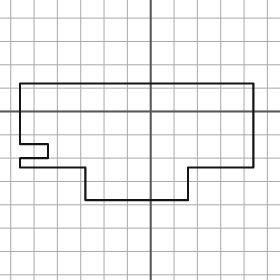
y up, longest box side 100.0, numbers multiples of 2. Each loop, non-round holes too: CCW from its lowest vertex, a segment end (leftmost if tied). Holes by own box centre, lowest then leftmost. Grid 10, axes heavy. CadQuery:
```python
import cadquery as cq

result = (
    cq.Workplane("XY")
    .moveTo(-28.0, -38.0)
    .lineTo(16.0, -38.0)
    .lineTo(16.0, -24.0)
    .lineTo(44.0, -24.0)
    .lineTo(44.0, 12.0)
    .lineTo(-56.0, 12.0)
    .lineTo(-56.0, -14.0)
    .lineTo(-44.0, -14.0)
    .lineTo(-44.0, -20.0)
    .lineTo(-56.0, -20.0)
    .lineTo(-56.0, -24.0)
    .lineTo(-28.0, -24.0)
    .close()
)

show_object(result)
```